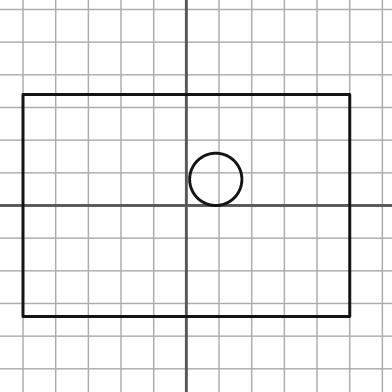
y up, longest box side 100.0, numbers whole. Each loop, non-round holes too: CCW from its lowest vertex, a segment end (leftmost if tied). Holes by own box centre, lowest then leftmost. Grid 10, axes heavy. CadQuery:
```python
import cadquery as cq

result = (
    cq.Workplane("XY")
    .moveTo(-50.0, -34.0)
    .lineTo(50.0, -34.0)
    .lineTo(50.0, 34.0)
    .lineTo(-50.0, 34.0)
    .close()
    .moveTo(9.0, 8.0)
    .circle(8.0)
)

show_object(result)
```